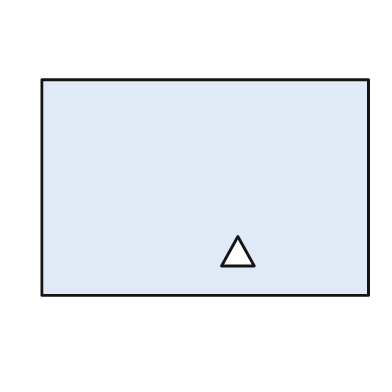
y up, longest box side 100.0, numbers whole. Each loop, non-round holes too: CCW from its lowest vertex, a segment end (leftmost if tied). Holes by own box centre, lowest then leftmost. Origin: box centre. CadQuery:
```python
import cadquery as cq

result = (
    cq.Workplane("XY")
    .moveTo(-50.0, -33.0)
    .lineTo(50.0, -33.0)
    .lineTo(50.0, 33.0)
    .lineTo(-50.0, 33.0)
    .close()
    .moveTo(5.0, -24.0)
    .lineTo(15.0, -24.0)
    .lineTo(10.0, -15.0)
    .close()
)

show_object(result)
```